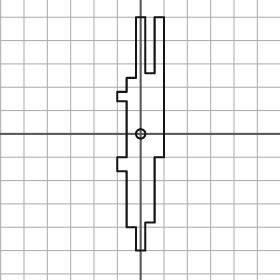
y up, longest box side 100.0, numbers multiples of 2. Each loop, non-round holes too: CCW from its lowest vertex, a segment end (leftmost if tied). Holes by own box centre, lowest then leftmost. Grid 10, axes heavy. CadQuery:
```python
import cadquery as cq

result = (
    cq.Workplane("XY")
    .moveTo(-2.0, -50.0)
    .lineTo(2.0, -50.0)
    .lineTo(2.0, -38.0)
    .lineTo(6.0, -38.0)
    .lineTo(6.0, -10.0)
    .lineTo(10.0, -10.0)
    .lineTo(10.0, 50.0)
    .lineTo(6.0, 50.0)
    .lineTo(6.0, 26.0)
    .lineTo(2.0, 26.0)
    .lineTo(2.0, 50.0)
    .lineTo(-2.0, 50.0)
    .lineTo(-2.0, 24.0)
    .lineTo(-6.0, 24.0)
    .lineTo(-6.0, 18.0)
    .lineTo(-10.0, 18.0)
    .lineTo(-10.0, 14.0)
    .lineTo(-6.0, 14.0)
    .lineTo(-6.0, -10.0)
    .lineTo(-10.0, -10.0)
    .lineTo(-10.0, -16.0)
    .lineTo(-6.0, -16.0)
    .lineTo(-6.0, -40.0)
    .lineTo(-2.0, -40.0)
    .close()
    .moveTo(0.0, 0.0)
    .circle(2.0)
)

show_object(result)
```